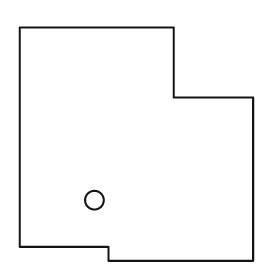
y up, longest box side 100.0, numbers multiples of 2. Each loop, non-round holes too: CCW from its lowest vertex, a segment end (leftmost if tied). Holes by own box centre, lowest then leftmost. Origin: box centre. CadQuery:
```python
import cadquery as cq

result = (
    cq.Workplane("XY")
    .moveTo(-12.0, -50.0)
    .lineTo(50.0, -50.0)
    .lineTo(50.0, 20.0)
    .lineTo(16.0, 20.0)
    .lineTo(16.0, 50.0)
    .lineTo(-50.0, 50.0)
    .lineTo(-50.0, -44.0)
    .lineTo(-12.0, -44.0)
    .close()
    .moveTo(-18.0, -24.0)
    .circle(4.0)
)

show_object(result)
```